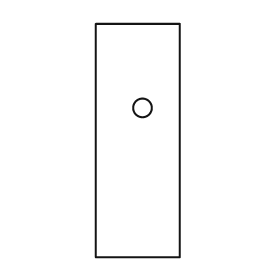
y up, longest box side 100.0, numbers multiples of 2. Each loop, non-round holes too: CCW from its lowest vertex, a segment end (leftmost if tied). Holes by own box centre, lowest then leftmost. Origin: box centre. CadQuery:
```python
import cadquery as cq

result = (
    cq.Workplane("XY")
    .moveTo(-18.0, -50.0)
    .lineTo(18.0, -50.0)
    .lineTo(18.0, 50.0)
    .lineTo(-18.0, 50.0)
    .close()
    .moveTo(2.0, 14.0)
    .circle(4.0)
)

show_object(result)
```